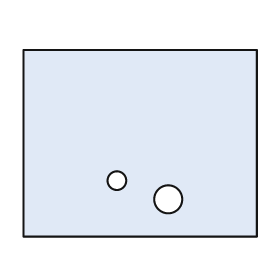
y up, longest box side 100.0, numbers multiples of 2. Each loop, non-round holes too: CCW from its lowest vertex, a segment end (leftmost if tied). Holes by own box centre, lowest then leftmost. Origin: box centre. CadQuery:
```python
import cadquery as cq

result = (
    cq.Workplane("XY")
    .moveTo(-50.0, -40.0)
    .lineTo(50.0, -40.0)
    .lineTo(50.0, 40.0)
    .lineTo(-50.0, 40.0)
    .close()
    .moveTo(12.0, -24.0)
    .circle(6.0)
    .moveTo(-10.0, -16.0)
    .circle(4.0)
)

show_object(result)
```